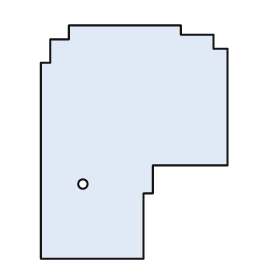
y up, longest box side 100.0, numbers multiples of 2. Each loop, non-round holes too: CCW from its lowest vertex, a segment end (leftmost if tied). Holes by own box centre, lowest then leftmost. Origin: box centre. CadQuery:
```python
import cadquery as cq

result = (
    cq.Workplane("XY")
    .moveTo(-40.0, -50.0)
    .lineTo(4.0, -50.0)
    .lineTo(4.0, -22.0)
    .lineTo(8.0, -22.0)
    .lineTo(8.0, -10.0)
    .lineTo(40.0, -10.0)
    .lineTo(40.0, 40.0)
    .lineTo(34.0, 40.0)
    .lineTo(34.0, 46.0)
    .lineTo(20.0, 46.0)
    .lineTo(20.0, 50.0)
    .lineTo(-28.0, 50.0)
    .lineTo(-28.0, 44.0)
    .lineTo(-36.0, 44.0)
    .lineTo(-36.0, 34.0)
    .lineTo(-40.0, 34.0)
    .close()
    .moveTo(-22.0, -18.0)
    .circle(2.0)
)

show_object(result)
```